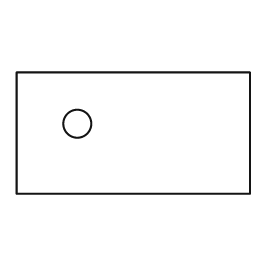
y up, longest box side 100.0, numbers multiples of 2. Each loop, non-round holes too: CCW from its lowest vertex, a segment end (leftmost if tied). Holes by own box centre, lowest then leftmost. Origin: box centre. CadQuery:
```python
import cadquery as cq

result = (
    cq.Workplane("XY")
    .moveTo(-50.0, -26.0)
    .lineTo(50.0, -26.0)
    .lineTo(50.0, 26.0)
    .lineTo(-50.0, 26.0)
    .close()
    .moveTo(-24.0, 4.0)
    .circle(6.0)
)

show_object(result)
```